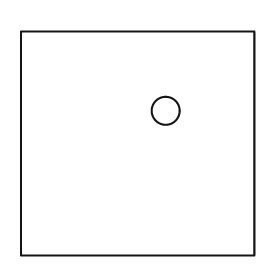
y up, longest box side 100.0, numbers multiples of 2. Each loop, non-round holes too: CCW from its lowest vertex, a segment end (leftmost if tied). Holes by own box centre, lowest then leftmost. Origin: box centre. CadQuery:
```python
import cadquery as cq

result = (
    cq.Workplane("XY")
    .moveTo(-50.0, -48.0)
    .lineTo(50.0, -48.0)
    .lineTo(50.0, 48.0)
    .lineTo(-50.0, 48.0)
    .close()
    .moveTo(12.0, 14.0)
    .circle(6.0)
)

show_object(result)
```